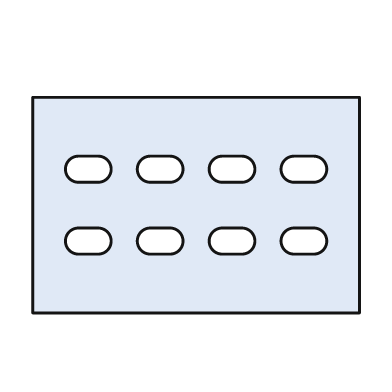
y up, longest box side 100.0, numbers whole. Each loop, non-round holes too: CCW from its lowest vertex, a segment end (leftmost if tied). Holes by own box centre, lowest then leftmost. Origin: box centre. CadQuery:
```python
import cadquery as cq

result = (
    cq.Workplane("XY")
    .moveTo(-50.0, -33.0)
    .lineTo(50.0, -33.0)
    .lineTo(50.0, 33.0)
    .lineTo(-50.0, 33.0)
    .close()
    .moveTo(-36.0, -15.0)
    .lineTo(-30.0, -15.0)
    .threePointArc((-26.0, -11.0), (-30.0, -7.0))
    .lineTo(-36.0, -7.0)
    .threePointArc((-40.0, -11.0), (-36.0, -15.0))
    .close()
    .moveTo(-14.0, -15.0)
    .lineTo(-8.0, -15.0)
    .threePointArc((-4.0, -11.0), (-8.0, -7.0))
    .lineTo(-14.0, -7.0)
    .threePointArc((-18.0, -11.0), (-14.0, -15.0))
    .close()
    .moveTo(8.0, -15.0)
    .lineTo(14.0, -15.0)
    .threePointArc((18.0, -11.0), (14.0, -7.0))
    .lineTo(8.0, -7.0)
    .threePointArc((4.0, -11.0), (8.0, -15.0))
    .close()
    .moveTo(30.0, -15.0)
    .lineTo(36.0, -15.0)
    .threePointArc((40.0, -11.0), (36.0, -7.0))
    .lineTo(30.0, -7.0)
    .threePointArc((26.0, -11.0), (30.0, -15.0))
    .close()
    .moveTo(-36.0, 7.0)
    .lineTo(-30.0, 7.0)
    .threePointArc((-26.0, 11.0), (-30.0, 15.0))
    .lineTo(-36.0, 15.0)
    .threePointArc((-40.0, 11.0), (-36.0, 7.0))
    .close()
    .moveTo(-14.0, 7.0)
    .lineTo(-8.0, 7.0)
    .threePointArc((-4.0, 11.0), (-8.0, 15.0))
    .lineTo(-14.0, 15.0)
    .threePointArc((-18.0, 11.0), (-14.0, 7.0))
    .close()
    .moveTo(8.0, 7.0)
    .lineTo(14.0, 7.0)
    .threePointArc((18.0, 11.0), (14.0, 15.0))
    .lineTo(8.0, 15.0)
    .threePointArc((4.0, 11.0), (8.0, 7.0))
    .close()
    .moveTo(30.0, 7.0)
    .lineTo(36.0, 7.0)
    .threePointArc((40.0, 11.0), (36.0, 15.0))
    .lineTo(30.0, 15.0)
    .threePointArc((26.0, 11.0), (30.0, 7.0))
    .close()
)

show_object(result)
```